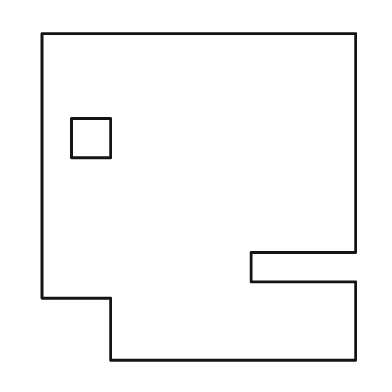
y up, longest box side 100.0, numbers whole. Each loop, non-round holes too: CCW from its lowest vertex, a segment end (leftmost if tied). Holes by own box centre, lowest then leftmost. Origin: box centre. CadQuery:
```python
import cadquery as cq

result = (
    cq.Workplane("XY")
    .moveTo(-27.0, -50.0)
    .lineTo(48.0, -50.0)
    .lineTo(48.0, -26.0)
    .lineTo(16.0, -26.0)
    .lineTo(16.0, -17.0)
    .lineTo(48.0, -17.0)
    .lineTo(48.0, 50.0)
    .lineTo(-48.0, 50.0)
    .lineTo(-48.0, -31.0)
    .lineTo(-27.0, -31.0)
    .close()
    .moveTo(-39.0, 12.0)
    .lineTo(-27.0, 12.0)
    .lineTo(-27.0, 24.0)
    .lineTo(-39.0, 24.0)
    .close()
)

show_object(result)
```